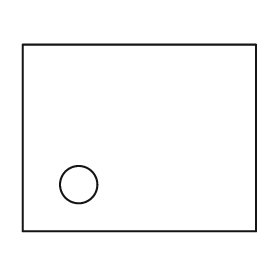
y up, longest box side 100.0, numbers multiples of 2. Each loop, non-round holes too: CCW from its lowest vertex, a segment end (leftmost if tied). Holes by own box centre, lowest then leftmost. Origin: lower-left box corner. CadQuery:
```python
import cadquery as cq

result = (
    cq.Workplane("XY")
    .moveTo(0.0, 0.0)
    .lineTo(100.0, 0.0)
    .lineTo(100.0, 80.0)
    .lineTo(0.0, 80.0)
    .close()
    .moveTo(24.0, 20.0)
    .circle(8.0)
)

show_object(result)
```